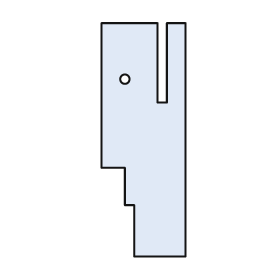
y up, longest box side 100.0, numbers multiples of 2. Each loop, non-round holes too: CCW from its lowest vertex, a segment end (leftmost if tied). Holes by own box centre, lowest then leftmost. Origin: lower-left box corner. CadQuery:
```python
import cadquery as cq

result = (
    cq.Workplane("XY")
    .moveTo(14.0, 0.0)
    .lineTo(36.0, 0.0)
    .lineTo(36.0, 100.0)
    .lineTo(28.0, 100.0)
    .lineTo(28.0, 66.0)
    .lineTo(24.0, 66.0)
    .lineTo(24.0, 100.0)
    .lineTo(0.0, 100.0)
    .lineTo(0.0, 38.0)
    .lineTo(10.0, 38.0)
    .lineTo(10.0, 22.0)
    .lineTo(14.0, 22.0)
    .close()
    .moveTo(10.0, 76.0)
    .circle(2.0)
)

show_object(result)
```